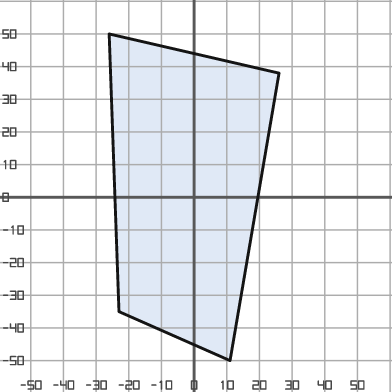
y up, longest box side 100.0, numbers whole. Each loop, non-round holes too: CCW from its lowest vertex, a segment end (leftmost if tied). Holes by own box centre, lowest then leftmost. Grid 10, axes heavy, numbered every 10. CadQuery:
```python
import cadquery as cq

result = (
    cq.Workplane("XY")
    .moveTo(11.0, -50.0)
    .lineTo(26.0, 38.0)
    .lineTo(-26.0, 50.0)
    .lineTo(-23.0, -35.0)
    .close()
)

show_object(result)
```